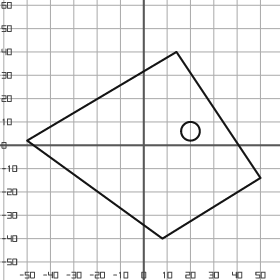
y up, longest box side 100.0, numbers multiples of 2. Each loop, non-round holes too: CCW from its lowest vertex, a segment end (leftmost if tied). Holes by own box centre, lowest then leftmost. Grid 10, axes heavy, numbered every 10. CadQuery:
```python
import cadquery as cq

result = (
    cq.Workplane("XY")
    .moveTo(8.0, -40.0)
    .lineTo(50.0, -14.0)
    .lineTo(14.0, 40.0)
    .lineTo(-50.0, 2.0)
    .close()
    .moveTo(20.0, 6.0)
    .circle(4.0)
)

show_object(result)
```